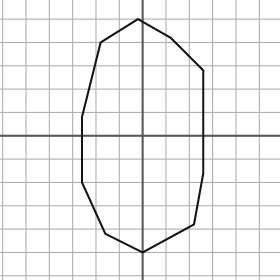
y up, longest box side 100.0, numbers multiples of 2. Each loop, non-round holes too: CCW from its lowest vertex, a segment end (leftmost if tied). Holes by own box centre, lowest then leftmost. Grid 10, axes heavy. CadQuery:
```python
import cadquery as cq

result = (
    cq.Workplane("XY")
    .moveTo(0.0, -50.0)
    .lineTo(22.0, -38.0)
    .lineTo(26.0, -16.0)
    .lineTo(26.0, 28.0)
    .lineTo(12.0, 42.0)
    .lineTo(-2.0, 50.0)
    .lineTo(-18.0, 40.0)
    .lineTo(-26.0, 8.0)
    .lineTo(-26.0, -20.0)
    .lineTo(-16.0, -42.0)
    .close()
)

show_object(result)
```